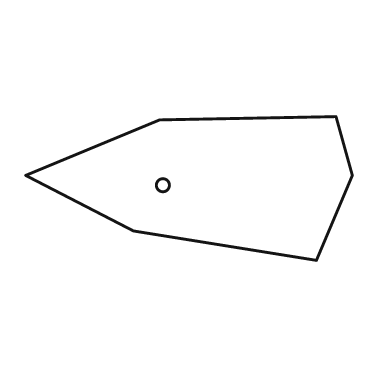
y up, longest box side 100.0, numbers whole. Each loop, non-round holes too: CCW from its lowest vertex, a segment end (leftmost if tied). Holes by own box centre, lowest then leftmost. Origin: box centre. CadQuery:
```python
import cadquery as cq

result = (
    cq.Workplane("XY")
    .moveTo(39.0, -22.0)
    .lineTo(50.0, 4.0)
    .lineTo(45.0, 22.0)
    .lineTo(-9.0, 21.0)
    .lineTo(-50.0, 4.0)
    .lineTo(-17.0, -13.0)
    .close()
    .moveTo(-8.0, 1.0)
    .circle(2.0)
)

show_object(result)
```